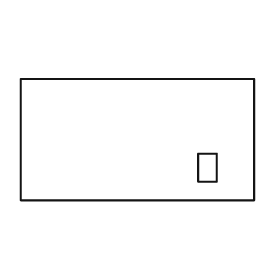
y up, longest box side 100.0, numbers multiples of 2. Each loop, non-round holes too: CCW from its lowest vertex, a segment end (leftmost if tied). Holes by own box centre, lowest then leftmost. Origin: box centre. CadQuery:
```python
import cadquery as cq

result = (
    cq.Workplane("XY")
    .moveTo(-50.0, -26.0)
    .lineTo(50.0, -26.0)
    .lineTo(50.0, 26.0)
    .lineTo(-50.0, 26.0)
    .close()
    .moveTo(26.0, -18.0)
    .lineTo(34.0, -18.0)
    .lineTo(34.0, -6.0)
    .lineTo(26.0, -6.0)
    .close()
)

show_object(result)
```